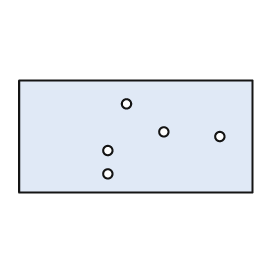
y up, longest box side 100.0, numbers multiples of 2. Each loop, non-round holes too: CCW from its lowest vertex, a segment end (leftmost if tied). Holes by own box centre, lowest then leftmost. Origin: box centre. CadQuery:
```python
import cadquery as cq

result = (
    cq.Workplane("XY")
    .moveTo(-50.0, -24.0)
    .lineTo(50.0, -24.0)
    .lineTo(50.0, 24.0)
    .lineTo(-50.0, 24.0)
    .close()
    .moveTo(-12.0, -16.0)
    .circle(2.0)
    .moveTo(-12.0, -6.0)
    .circle(2.0)
    .moveTo(36.0, 0.0)
    .circle(2.0)
    .moveTo(12.0, 2.0)
    .circle(2.0)
    .moveTo(-4.0, 14.0)
    .circle(2.0)
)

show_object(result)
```